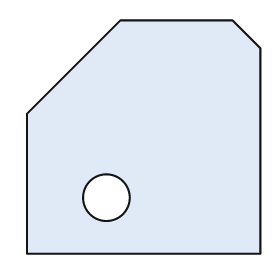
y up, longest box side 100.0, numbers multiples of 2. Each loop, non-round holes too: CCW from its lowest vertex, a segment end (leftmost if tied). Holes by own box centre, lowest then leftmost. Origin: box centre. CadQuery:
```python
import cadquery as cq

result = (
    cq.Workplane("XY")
    .moveTo(-50.0, -50.0)
    .lineTo(50.0, -50.0)
    .lineTo(50.0, 38.0)
    .lineTo(38.0, 50.0)
    .lineTo(-10.0, 50.0)
    .lineTo(-50.0, 10.0)
    .close()
    .moveTo(-16.0, -26.0)
    .circle(10.0)
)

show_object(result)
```